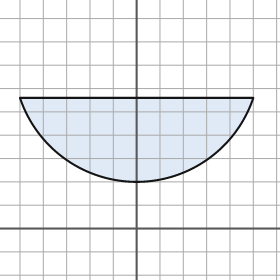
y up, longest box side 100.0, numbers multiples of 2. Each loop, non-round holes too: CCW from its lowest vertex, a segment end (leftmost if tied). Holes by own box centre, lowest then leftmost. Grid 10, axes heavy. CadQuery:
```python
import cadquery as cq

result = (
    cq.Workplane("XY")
    .moveTo(-50.0, 56.0)
    .threePointArc((0.0, 20.0), (50.0, 56.0))
    .close()
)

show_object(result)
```